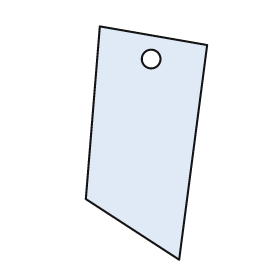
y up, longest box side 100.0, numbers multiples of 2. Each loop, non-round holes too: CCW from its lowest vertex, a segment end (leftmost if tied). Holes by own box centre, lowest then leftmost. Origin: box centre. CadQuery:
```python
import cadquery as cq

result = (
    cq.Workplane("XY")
    .moveTo(14.0, -50.0)
    .lineTo(26.0, 42.0)
    .lineTo(-20.0, 50.0)
    .lineTo(-26.0, -24.0)
    .close()
    .moveTo(2.0, 36.0)
    .circle(4.0)
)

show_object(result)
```